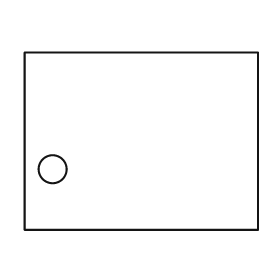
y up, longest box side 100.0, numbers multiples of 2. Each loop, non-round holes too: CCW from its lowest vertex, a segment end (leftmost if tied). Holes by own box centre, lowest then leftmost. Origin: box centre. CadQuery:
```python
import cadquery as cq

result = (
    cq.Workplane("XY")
    .moveTo(-50.0, -38.0)
    .lineTo(50.0, -38.0)
    .lineTo(50.0, 38.0)
    .lineTo(-50.0, 38.0)
    .close()
    .moveTo(-38.0, -12.0)
    .circle(6.0)
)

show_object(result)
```